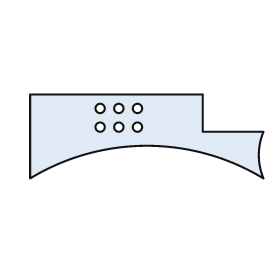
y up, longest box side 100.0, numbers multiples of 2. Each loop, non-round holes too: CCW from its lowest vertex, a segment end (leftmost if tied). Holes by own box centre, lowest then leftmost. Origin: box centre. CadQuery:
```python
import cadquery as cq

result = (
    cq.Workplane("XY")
    .moveTo(-50.0, -18.0)
    .threePointArc((0.0, -4.0), (50.0, -18.0))
    .threePointArc((48.0, -8.0), (50.0, 2.0))
    .lineTo(24.0, 2.0)
    .lineTo(24.0, 18.0)
    .lineTo(-50.0, 18.0)
    .close()
    .moveTo(-20.0, 4.0)
    .circle(2.0)
    .moveTo(-12.0, 4.0)
    .circle(2.0)
    .moveTo(-4.0, 4.0)
    .circle(2.0)
    .moveTo(-20.0, 12.0)
    .circle(2.0)
    .moveTo(-12.0, 12.0)
    .circle(2.0)
    .moveTo(-4.0, 12.0)
    .circle(2.0)
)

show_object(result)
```